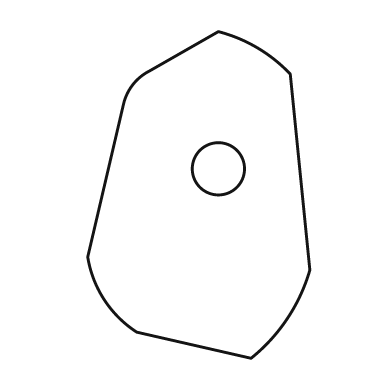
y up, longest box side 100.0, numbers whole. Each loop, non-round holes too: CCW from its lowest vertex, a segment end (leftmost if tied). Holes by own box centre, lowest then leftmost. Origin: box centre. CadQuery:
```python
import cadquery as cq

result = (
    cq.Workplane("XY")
    .moveTo(16.0, -50.0)
    .threePointArc((27.0, -38.0), (34.0, -23.0))
    .lineTo(28.0, 37.0)
    .threePointArc((18.0, 45.0), (6.0, 50.0))
    .lineTo(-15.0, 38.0)
    .threePointArc((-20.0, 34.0), (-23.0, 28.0))
    .lineTo(-34.0, -19.0)
    .threePointArc((-29.0, -32.0), (-19.0, -42.0))
    .close()
    .moveTo(6.0, 8.0)
    .circle(8.0)
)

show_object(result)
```